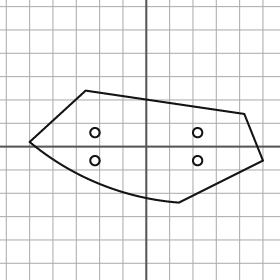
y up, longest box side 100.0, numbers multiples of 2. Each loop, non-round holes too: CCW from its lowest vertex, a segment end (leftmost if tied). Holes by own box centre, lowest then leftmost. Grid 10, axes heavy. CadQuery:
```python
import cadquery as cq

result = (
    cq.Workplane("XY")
    .moveTo(14.0, -24.0)
    .lineTo(50.0, -6.0)
    .lineTo(42.0, 14.0)
    .lineTo(-26.0, 24.0)
    .lineTo(-50.0, 2.0)
    .threePointArc((-20.0, -16.0), (14.0, -24.0))
    .close()
    .moveTo(-22.0, -6.0)
    .circle(2.0)
    .moveTo(22.0, -6.0)
    .circle(2.0)
    .moveTo(-22.0, 6.0)
    .circle(2.0)
    .moveTo(22.0, 6.0)
    .circle(2.0)
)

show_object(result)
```